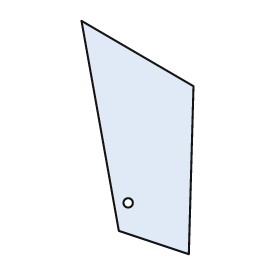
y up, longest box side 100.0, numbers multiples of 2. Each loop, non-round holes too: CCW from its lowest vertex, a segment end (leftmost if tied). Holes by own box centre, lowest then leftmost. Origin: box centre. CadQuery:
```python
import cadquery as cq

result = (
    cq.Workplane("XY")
    .moveTo(22.0, -50.0)
    .lineTo(24.0, 22.0)
    .lineTo(-24.0, 50.0)
    .lineTo(-8.0, -40.0)
    .close()
    .moveTo(-4.0, -28.0)
    .circle(2.0)
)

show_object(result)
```